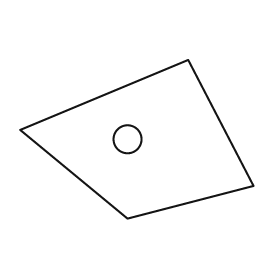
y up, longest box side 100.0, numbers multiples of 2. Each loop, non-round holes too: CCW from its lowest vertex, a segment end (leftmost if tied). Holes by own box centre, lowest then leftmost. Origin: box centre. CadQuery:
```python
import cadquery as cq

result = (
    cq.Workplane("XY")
    .moveTo(-4.0, -34.0)
    .lineTo(50.0, -20.0)
    .lineTo(22.0, 34.0)
    .lineTo(-50.0, 4.0)
    .close()
    .moveTo(-4.0, 0.0)
    .circle(6.0)
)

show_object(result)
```